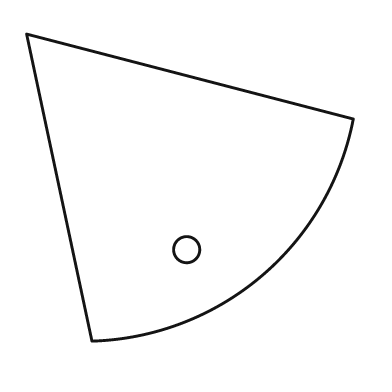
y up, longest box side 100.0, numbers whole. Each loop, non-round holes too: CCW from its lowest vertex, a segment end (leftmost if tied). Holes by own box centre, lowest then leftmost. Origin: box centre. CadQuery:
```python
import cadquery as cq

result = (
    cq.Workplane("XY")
    .moveTo(-30.0, -47.0)
    .threePointArc((22.0, -27.0), (50.0, 21.0))
    .lineTo(-50.0, 47.0)
    .close()
    .moveTo(-1.0, -19.0)
    .circle(4.0)
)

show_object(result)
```